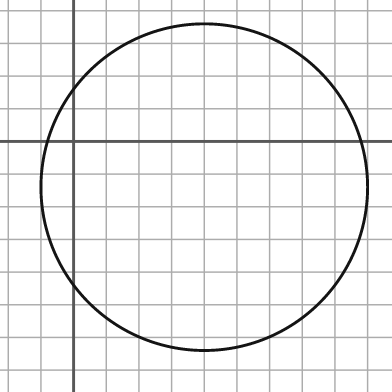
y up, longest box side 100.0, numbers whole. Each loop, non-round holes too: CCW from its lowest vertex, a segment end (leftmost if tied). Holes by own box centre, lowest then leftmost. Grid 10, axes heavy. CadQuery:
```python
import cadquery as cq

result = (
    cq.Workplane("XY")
    .moveTo(40.0, -14.0)
    .circle(50.0)
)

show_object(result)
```